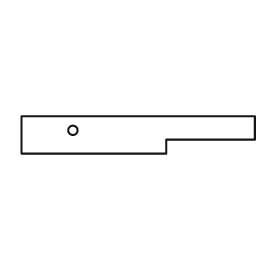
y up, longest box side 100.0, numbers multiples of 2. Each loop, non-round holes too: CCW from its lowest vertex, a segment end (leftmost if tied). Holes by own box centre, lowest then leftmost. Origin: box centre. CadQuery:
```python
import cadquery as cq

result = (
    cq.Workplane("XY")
    .moveTo(-50.0, -8.0)
    .lineTo(12.0, -8.0)
    .lineTo(12.0, -2.0)
    .lineTo(50.0, -2.0)
    .lineTo(50.0, 8.0)
    .lineTo(-50.0, 8.0)
    .close()
    .moveTo(-28.0, 2.0)
    .circle(2.0)
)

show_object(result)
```